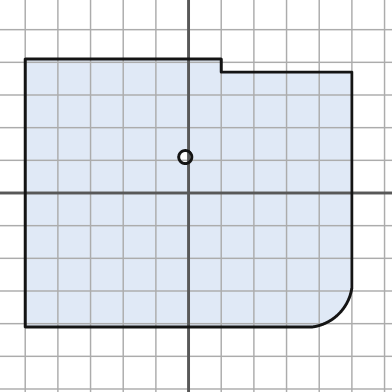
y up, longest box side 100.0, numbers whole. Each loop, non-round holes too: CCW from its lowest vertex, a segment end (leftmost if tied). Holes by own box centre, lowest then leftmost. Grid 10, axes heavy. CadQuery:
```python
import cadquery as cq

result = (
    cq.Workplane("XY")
    .moveTo(-50.0, -41.0)
    .lineTo(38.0, -41.0)
    .threePointArc((46.0, -37.0), (50.0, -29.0))
    .lineTo(50.0, 37.0)
    .lineTo(10.0, 37.0)
    .lineTo(10.0, 41.0)
    .lineTo(-50.0, 41.0)
    .close()
    .moveTo(-1.0, 11.0)
    .circle(2.0)
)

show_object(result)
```